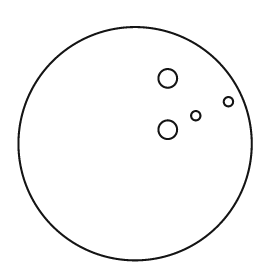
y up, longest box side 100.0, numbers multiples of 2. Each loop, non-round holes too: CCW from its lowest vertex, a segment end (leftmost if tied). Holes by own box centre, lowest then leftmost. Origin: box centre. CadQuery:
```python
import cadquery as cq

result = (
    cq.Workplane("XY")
    .moveTo(0.0, 0.0)
    .circle(50.0)
    .moveTo(14.0, 6.0)
    .circle(4.0)
    .moveTo(26.0, 12.0)
    .circle(2.0)
    .moveTo(40.0, 18.0)
    .circle(2.0)
    .moveTo(14.0, 28.0)
    .circle(4.0)
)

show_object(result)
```